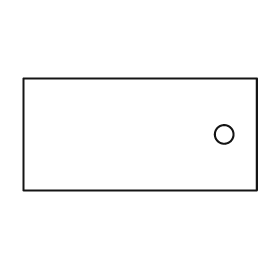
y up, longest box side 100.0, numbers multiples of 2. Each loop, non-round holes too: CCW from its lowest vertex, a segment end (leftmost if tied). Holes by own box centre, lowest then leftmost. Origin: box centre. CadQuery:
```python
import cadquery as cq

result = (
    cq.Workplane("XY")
    .moveTo(-50.0, -24.0)
    .lineTo(50.0, -24.0)
    .lineTo(50.0, 24.0)
    .lineTo(-50.0, 24.0)
    .close()
    .moveTo(36.0, 0.0)
    .circle(4.0)
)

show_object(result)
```